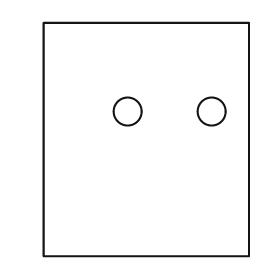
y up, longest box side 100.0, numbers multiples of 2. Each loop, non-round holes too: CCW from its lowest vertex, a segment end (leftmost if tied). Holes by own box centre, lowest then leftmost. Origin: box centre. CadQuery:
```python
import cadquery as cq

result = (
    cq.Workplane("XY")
    .moveTo(-44.0, -50.0)
    .lineTo(44.0, -50.0)
    .lineTo(44.0, 50.0)
    .lineTo(-44.0, 50.0)
    .close()
    .moveTo(-8.0, 12.0)
    .circle(6.0)
    .moveTo(28.0, 12.0)
    .circle(6.0)
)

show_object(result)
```